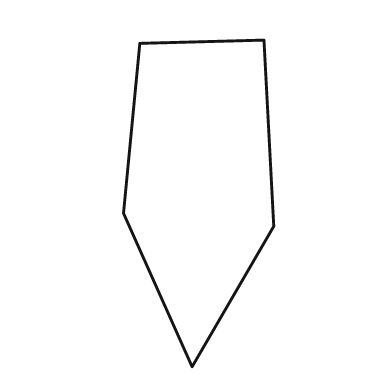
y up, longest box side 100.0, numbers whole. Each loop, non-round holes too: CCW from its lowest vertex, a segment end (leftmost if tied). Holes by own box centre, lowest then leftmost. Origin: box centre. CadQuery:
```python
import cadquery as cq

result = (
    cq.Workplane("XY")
    .moveTo(-2.0, -50.0)
    .lineTo(23.0, -7.0)
    .lineTo(20.0, 50.0)
    .lineTo(-18.0, 49.0)
    .lineTo(-23.0, -3.0)
    .close()
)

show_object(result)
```